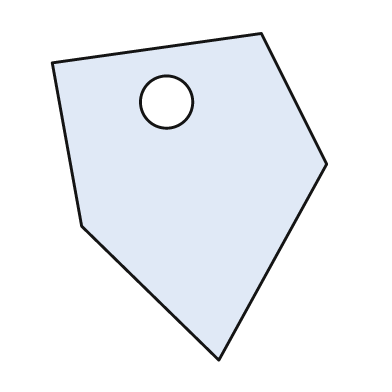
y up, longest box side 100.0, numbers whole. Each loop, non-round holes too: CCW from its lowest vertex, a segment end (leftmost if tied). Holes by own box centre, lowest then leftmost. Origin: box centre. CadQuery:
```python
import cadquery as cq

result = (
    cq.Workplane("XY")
    .moveTo(9.0, -50.0)
    .lineTo(42.0, 10.0)
    .lineTo(22.0, 50.0)
    .lineTo(-42.0, 41.0)
    .lineTo(-33.0, -9.0)
    .close()
    .moveTo(-7.0, 29.0)
    .circle(8.0)
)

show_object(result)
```